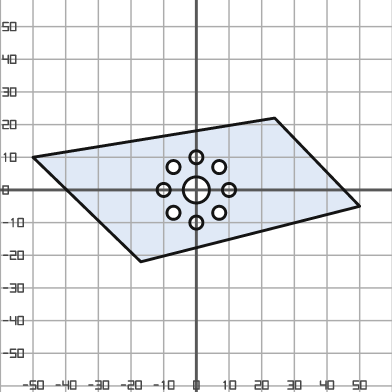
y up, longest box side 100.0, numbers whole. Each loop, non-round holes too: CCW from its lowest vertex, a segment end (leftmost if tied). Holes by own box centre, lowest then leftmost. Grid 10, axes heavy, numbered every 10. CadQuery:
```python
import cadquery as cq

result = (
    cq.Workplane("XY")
    .moveTo(-17.0, -22.0)
    .lineTo(50.0, -5.0)
    .lineTo(24.0, 22.0)
    .lineTo(-50.0, 10.0)
    .close()
    .moveTo(0.0, -10.0)
    .circle(2.0)
    .moveTo(-7.0, -7.0)
    .circle(2.0)
    .moveTo(7.0, -7.0)
    .circle(2.0)
    .moveTo(-10.0, 0.0)
    .circle(2.0)
    .moveTo(0.0, 0.0)
    .circle(4.0)
    .moveTo(10.0, 0.0)
    .circle(2.0)
    .moveTo(-7.0, 7.0)
    .circle(2.0)
    .moveTo(7.0, 7.0)
    .circle(2.0)
    .moveTo(0.0, 10.0)
    .circle(2.0)
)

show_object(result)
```